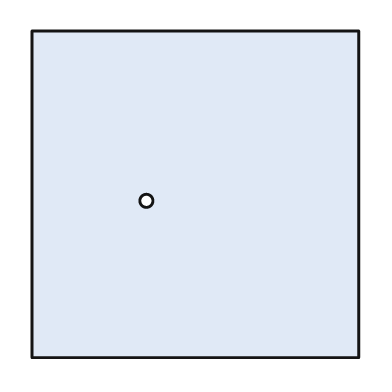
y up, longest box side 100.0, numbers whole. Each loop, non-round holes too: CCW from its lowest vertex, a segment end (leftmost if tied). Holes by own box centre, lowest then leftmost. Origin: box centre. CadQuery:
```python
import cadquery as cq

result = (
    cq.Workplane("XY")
    .moveTo(-50.0, -50.0)
    .lineTo(50.0, -50.0)
    .lineTo(50.0, 50.0)
    .lineTo(-50.0, 50.0)
    .close()
    .moveTo(-15.0, -2.0)
    .circle(2.0)
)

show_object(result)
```